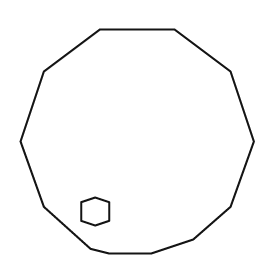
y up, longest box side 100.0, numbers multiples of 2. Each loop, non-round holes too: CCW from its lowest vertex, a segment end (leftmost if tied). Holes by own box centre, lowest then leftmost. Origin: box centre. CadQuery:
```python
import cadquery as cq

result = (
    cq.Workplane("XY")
    .moveTo(-12.0, -48.0)
    .lineTo(6.0, -48.0)
    .lineTo(24.0, -42.0)
    .lineTo(40.0, -28.0)
    .lineTo(50.0, 0.0)
    .lineTo(40.0, 30.0)
    .lineTo(16.0, 48.0)
    .lineTo(-16.0, 48.0)
    .lineTo(-40.0, 30.0)
    .lineTo(-50.0, 0.0)
    .lineTo(-40.0, -28.0)
    .lineTo(-20.0, -46.0)
    .close()
    .moveTo(-18.0, -36.0)
    .lineTo(-12.0, -34.0)
    .lineTo(-12.0, -26.0)
    .lineTo(-18.0, -24.0)
    .lineTo(-24.0, -26.0)
    .lineTo(-24.0, -34.0)
    .close()
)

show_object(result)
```